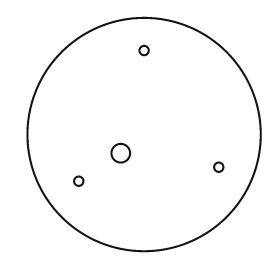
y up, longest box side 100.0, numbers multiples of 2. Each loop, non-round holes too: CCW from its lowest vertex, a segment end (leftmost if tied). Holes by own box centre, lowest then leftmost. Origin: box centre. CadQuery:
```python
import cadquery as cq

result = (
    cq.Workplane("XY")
    .moveTo(0.0, 0.0)
    .circle(50.0)
    .moveTo(-28.0, -20.0)
    .circle(2.0)
    .moveTo(32.0, -14.0)
    .circle(2.0)
    .moveTo(-10.0, -8.0)
    .circle(4.0)
    .moveTo(0.0, 36.0)
    .circle(2.0)
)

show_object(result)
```